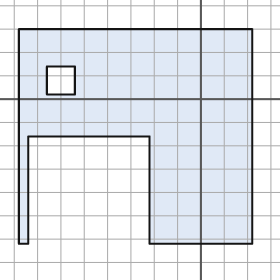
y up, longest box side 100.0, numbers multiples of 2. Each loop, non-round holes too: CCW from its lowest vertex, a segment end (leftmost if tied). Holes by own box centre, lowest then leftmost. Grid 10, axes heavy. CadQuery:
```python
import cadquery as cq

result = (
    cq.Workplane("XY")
    .moveTo(-78.0, -62.0)
    .lineTo(-74.0, -62.0)
    .lineTo(-74.0, -16.0)
    .lineTo(-22.0, -16.0)
    .lineTo(-22.0, -62.0)
    .lineTo(22.0, -62.0)
    .lineTo(22.0, 30.0)
    .lineTo(-78.0, 30.0)
    .close()
    .moveTo(-66.0, 2.0)
    .lineTo(-54.0, 2.0)
    .lineTo(-54.0, 14.0)
    .lineTo(-66.0, 14.0)
    .close()
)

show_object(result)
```